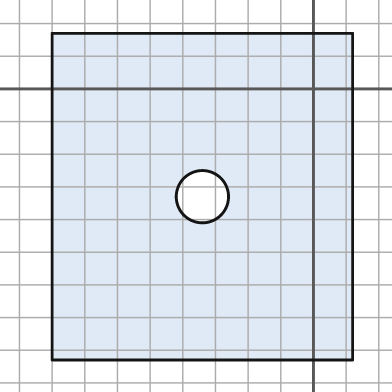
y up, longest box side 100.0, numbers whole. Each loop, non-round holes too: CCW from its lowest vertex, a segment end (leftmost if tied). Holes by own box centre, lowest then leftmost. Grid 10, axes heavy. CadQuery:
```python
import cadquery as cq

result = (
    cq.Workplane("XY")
    .moveTo(-80.0, -83.0)
    .lineTo(12.0, -83.0)
    .lineTo(12.0, 17.0)
    .lineTo(-80.0, 17.0)
    .close()
    .moveTo(-34.0, -33.0)
    .circle(8.0)
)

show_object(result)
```